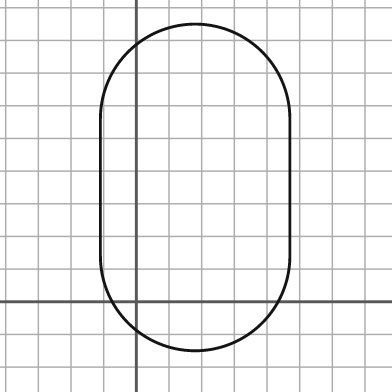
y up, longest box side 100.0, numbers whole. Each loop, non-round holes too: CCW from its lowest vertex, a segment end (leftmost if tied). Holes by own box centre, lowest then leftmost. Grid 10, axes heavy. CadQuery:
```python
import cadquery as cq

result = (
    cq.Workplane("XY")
    .moveTo(-11.0, 14.0)
    .threePointArc((18.0, -15.0), (47.0, 14.0))
    .lineTo(47.0, 56.0)
    .threePointArc((18.0, 85.0), (-11.0, 56.0))
    .close()
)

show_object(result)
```